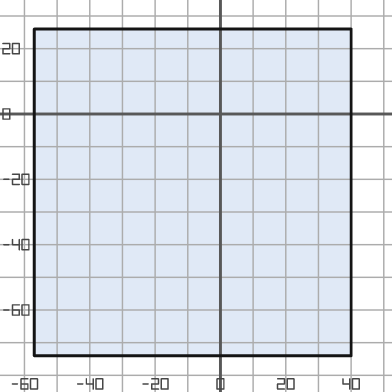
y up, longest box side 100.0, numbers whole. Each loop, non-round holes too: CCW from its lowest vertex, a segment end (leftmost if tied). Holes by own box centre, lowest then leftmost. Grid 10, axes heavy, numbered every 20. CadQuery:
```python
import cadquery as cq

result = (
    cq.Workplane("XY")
    .moveTo(-57.0, -74.0)
    .lineTo(40.0, -74.0)
    .lineTo(40.0, 26.0)
    .lineTo(-57.0, 26.0)
    .close()
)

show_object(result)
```